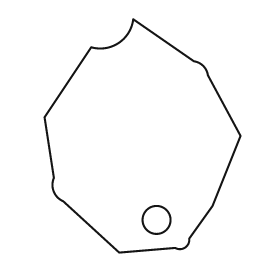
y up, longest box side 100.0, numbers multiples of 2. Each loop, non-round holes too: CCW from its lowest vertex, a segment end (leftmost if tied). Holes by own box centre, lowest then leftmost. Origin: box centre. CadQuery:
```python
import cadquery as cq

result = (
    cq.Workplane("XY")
    .moveTo(-10.0, -50.0)
    .lineTo(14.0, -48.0)
    .threePointArc((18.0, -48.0), (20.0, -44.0))
    .lineTo(30.0, -30.0)
    .lineTo(42.0, 0.0)
    .lineTo(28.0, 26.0)
    .threePointArc((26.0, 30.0), (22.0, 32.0))
    .lineTo(-4.0, 50.0)
    .threePointArc((-10.0, 40.0), (-22.0, 38.0))
    .lineTo(-42.0, 8.0)
    .lineTo(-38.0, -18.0)
    .threePointArc((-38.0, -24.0), (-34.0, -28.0))
    .close()
    .moveTo(6.0, -36.0)
    .circle(6.0)
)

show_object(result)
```